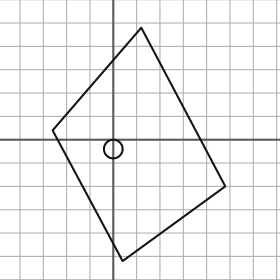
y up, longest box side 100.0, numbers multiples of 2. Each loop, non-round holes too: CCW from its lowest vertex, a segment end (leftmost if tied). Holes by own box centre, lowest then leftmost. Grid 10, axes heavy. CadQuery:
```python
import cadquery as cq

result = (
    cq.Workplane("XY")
    .moveTo(4.0, -52.0)
    .lineTo(48.0, -20.0)
    .lineTo(12.0, 48.0)
    .lineTo(-26.0, 4.0)
    .close()
    .moveTo(0.0, -4.0)
    .circle(4.0)
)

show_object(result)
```